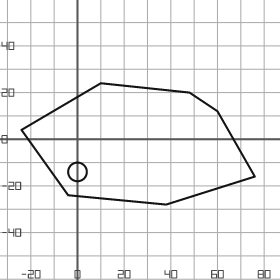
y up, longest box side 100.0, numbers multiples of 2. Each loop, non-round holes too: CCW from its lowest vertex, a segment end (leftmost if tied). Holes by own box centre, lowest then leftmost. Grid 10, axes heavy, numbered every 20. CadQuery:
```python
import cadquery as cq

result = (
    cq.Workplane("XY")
    .moveTo(38.0, -28.0)
    .lineTo(76.0, -16.0)
    .lineTo(60.0, 12.0)
    .lineTo(48.0, 20.0)
    .lineTo(10.0, 24.0)
    .lineTo(-24.0, 4.0)
    .lineTo(-4.0, -24.0)
    .close()
    .moveTo(0.0, -14.0)
    .circle(4.0)
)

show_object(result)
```